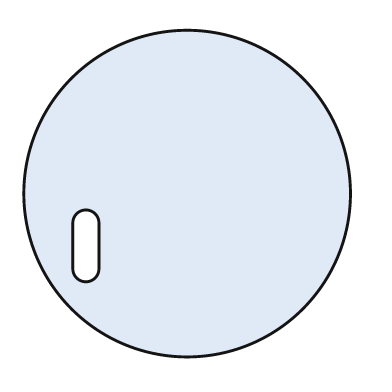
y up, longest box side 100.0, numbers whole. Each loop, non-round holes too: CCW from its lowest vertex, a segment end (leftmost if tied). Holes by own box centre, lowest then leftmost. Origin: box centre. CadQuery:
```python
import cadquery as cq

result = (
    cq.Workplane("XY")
    .moveTo(0.0, 0.0)
    .circle(50.0)
    .moveTo(-35.0, -23.0)
    .threePointArc((-31.0, -27.0), (-27.0, -23.0))
    .lineTo(-27.0, -9.0)
    .threePointArc((-31.0, -5.0), (-35.0, -9.0))
    .close()
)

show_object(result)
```